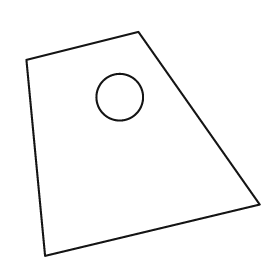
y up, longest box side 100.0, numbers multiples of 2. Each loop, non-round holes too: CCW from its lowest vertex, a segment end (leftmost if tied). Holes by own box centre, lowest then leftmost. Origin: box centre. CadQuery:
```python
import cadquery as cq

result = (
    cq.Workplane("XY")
    .moveTo(-42.0, -48.0)
    .lineTo(50.0, -26.0)
    .lineTo(-2.0, 48.0)
    .lineTo(-50.0, 36.0)
    .close()
    .moveTo(-10.0, 20.0)
    .circle(10.0)
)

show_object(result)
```